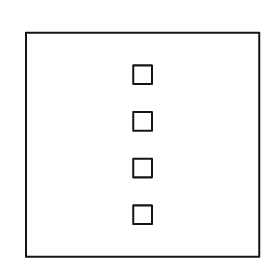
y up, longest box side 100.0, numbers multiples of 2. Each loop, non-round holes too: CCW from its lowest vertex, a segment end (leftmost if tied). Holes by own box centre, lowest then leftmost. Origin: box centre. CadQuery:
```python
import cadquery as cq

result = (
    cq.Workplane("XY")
    .moveTo(-50.0, -48.0)
    .lineTo(50.0, -48.0)
    .lineTo(50.0, 48.0)
    .lineTo(-50.0, 48.0)
    .close()
    .moveTo(-4.0, -34.0)
    .lineTo(4.0, -34.0)
    .lineTo(4.0, -26.0)
    .lineTo(-4.0, -26.0)
    .close()
    .moveTo(-4.0, -14.0)
    .lineTo(4.0, -14.0)
    .lineTo(4.0, -6.0)
    .lineTo(-4.0, -6.0)
    .close()
    .moveTo(-4.0, 6.0)
    .lineTo(4.0, 6.0)
    .lineTo(4.0, 14.0)
    .lineTo(-4.0, 14.0)
    .close()
    .moveTo(-4.0, 26.0)
    .lineTo(4.0, 26.0)
    .lineTo(4.0, 34.0)
    .lineTo(-4.0, 34.0)
    .close()
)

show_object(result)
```